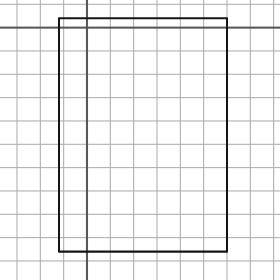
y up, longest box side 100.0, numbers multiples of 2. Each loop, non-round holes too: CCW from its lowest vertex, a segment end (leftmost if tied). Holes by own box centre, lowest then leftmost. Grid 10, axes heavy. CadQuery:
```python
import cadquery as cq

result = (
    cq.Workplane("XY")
    .moveTo(-12.0, -96.0)
    .lineTo(60.0, -96.0)
    .lineTo(60.0, 4.0)
    .lineTo(-12.0, 4.0)
    .close()
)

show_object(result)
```